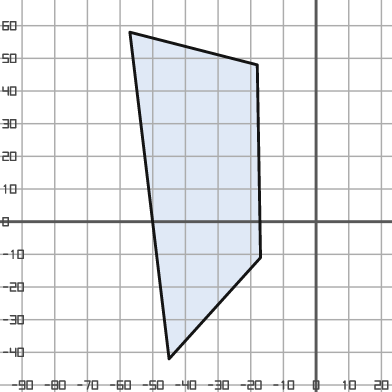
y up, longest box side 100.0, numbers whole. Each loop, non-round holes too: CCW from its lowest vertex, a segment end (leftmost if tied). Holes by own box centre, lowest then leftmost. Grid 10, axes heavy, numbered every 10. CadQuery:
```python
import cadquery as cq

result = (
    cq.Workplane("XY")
    .moveTo(-45.0, -42.0)
    .lineTo(-17.0, -11.0)
    .lineTo(-18.0, 48.0)
    .lineTo(-57.0, 58.0)
    .close()
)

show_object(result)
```